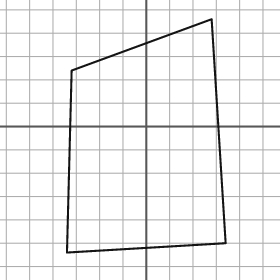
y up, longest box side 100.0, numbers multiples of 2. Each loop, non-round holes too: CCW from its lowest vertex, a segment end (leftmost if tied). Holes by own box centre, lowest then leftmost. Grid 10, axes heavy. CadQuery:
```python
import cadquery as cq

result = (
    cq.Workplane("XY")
    .moveTo(-34.0, -54.0)
    .lineTo(34.0, -50.0)
    .lineTo(28.0, 46.0)
    .lineTo(-32.0, 24.0)
    .close()
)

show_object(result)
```